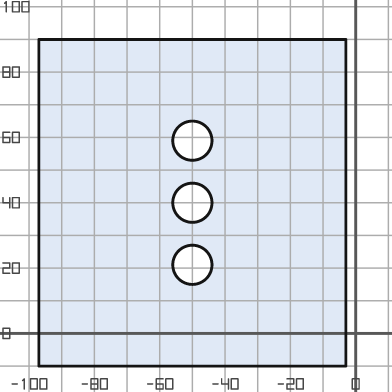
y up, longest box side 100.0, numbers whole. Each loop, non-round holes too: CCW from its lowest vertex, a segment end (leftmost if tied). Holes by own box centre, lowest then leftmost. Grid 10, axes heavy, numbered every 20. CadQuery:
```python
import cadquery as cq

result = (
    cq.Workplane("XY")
    .moveTo(-97.0, -10.0)
    .lineTo(-3.0, -10.0)
    .lineTo(-3.0, 90.0)
    .lineTo(-97.0, 90.0)
    .close()
    .moveTo(-50.0, 21.0)
    .circle(6.0)
    .moveTo(-50.0, 40.0)
    .circle(6.0)
    .moveTo(-50.0, 59.0)
    .circle(6.0)
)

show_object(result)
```